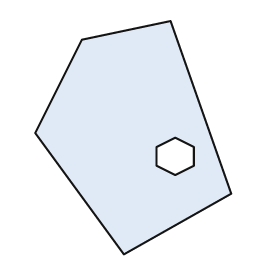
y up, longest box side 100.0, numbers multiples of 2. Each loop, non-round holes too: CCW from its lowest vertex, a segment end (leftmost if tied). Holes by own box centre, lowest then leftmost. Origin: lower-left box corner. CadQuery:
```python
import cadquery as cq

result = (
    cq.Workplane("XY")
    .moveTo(38.0, 0.0)
    .lineTo(84.0, 26.0)
    .lineTo(58.0, 100.0)
    .lineTo(20.0, 92.0)
    .lineTo(0.0, 52.0)
    .close()
    .moveTo(60.0, 34.0)
    .lineTo(68.0, 38.0)
    .lineTo(68.0, 46.0)
    .lineTo(60.0, 50.0)
    .lineTo(52.0, 46.0)
    .lineTo(52.0, 38.0)
    .close()
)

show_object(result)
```